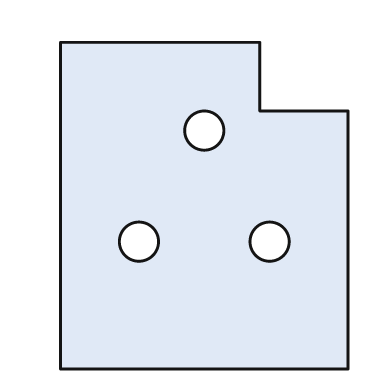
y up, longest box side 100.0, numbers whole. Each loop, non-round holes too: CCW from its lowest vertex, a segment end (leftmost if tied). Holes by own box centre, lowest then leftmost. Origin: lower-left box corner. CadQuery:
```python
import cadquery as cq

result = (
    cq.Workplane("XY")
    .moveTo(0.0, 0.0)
    .lineTo(88.0, 0.0)
    .lineTo(88.0, 79.0)
    .lineTo(61.0, 79.0)
    .lineTo(61.0, 100.0)
    .lineTo(0.0, 100.0)
    .close()
    .moveTo(24.0, 39.0)
    .circle(6.0)
    .moveTo(64.0, 39.0)
    .circle(6.0)
    .moveTo(44.0, 73.0)
    .circle(6.0)
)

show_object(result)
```